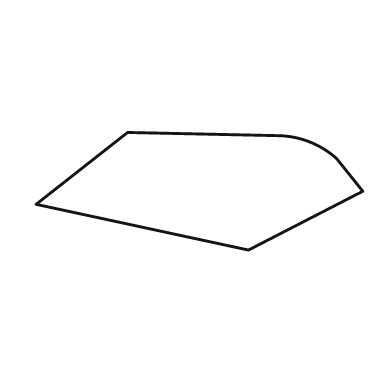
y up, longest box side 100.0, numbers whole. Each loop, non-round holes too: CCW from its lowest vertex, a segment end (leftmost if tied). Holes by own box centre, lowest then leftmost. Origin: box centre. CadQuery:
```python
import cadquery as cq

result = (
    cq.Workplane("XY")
    .moveTo(15.0, -18.0)
    .lineTo(50.0, 0.0)
    .lineTo(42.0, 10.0)
    .threePointArc((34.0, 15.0), (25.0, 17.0))
    .lineTo(-22.0, 18.0)
    .lineTo(-50.0, -4.0)
    .close()
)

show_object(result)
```